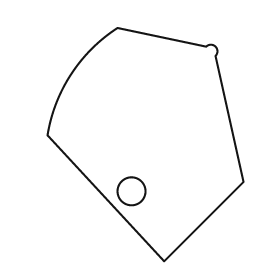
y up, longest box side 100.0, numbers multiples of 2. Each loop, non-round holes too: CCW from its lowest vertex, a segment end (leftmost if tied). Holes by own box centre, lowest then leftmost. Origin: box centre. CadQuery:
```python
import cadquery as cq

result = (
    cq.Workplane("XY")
    .moveTo(8.0, -50.0)
    .lineTo(42.0, -16.0)
    .lineTo(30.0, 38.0)
    .threePointArc((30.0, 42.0), (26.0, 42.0))
    .lineTo(-12.0, 50.0)
    .threePointArc((-32.0, 30.0), (-42.0, 4.0))
    .close()
    .moveTo(-6.0, -20.0)
    .circle(6.0)
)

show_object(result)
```